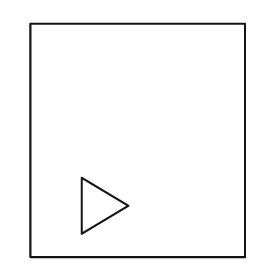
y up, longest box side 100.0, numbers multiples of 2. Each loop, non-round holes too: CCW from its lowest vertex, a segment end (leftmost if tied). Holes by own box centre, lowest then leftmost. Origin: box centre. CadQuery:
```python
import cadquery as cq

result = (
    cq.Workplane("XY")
    .moveTo(-46.0, -50.0)
    .lineTo(46.0, -50.0)
    .lineTo(46.0, 50.0)
    .lineTo(-46.0, 50.0)
    .close()
    .moveTo(-24.0, -40.0)
    .lineTo(-4.0, -28.0)
    .lineTo(-24.0, -16.0)
    .close()
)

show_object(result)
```